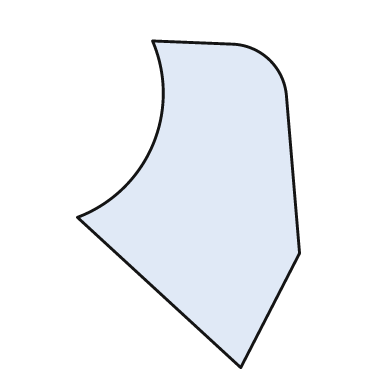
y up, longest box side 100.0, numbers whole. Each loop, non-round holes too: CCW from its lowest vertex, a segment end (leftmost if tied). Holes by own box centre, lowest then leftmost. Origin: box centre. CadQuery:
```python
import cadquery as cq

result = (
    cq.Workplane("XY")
    .moveTo(16.0, -50.0)
    .lineTo(34.0, -15.0)
    .lineTo(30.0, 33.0)
    .threePointArc((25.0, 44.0), (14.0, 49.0))
    .lineTo(-11.0, 50.0)
    .threePointArc((-11.0, 18.0), (-34.0, -4.0))
    .close()
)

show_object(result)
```